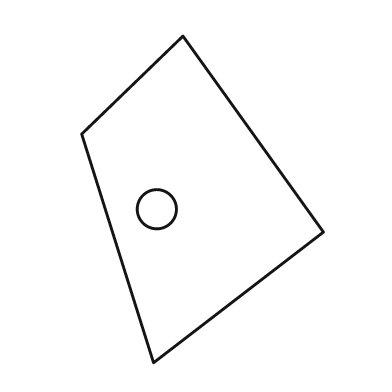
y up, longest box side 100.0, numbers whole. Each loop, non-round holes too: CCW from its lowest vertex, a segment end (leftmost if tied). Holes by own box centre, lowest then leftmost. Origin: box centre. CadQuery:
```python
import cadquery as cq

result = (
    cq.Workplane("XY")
    .moveTo(-15.0, -50.0)
    .lineTo(37.0, -10.0)
    .lineTo(-6.0, 50.0)
    .lineTo(-37.0, 20.0)
    .close()
    .moveTo(-14.0, -3.0)
    .circle(6.0)
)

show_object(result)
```